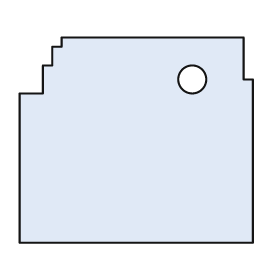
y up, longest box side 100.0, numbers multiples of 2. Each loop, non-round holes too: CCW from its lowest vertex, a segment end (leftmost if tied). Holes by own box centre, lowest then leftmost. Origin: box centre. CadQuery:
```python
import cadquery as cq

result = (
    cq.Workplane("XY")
    .moveTo(-50.0, -44.0)
    .lineTo(50.0, -44.0)
    .lineTo(50.0, 26.0)
    .lineTo(46.0, 26.0)
    .lineTo(46.0, 44.0)
    .lineTo(-32.0, 44.0)
    .lineTo(-32.0, 40.0)
    .lineTo(-36.0, 40.0)
    .lineTo(-36.0, 32.0)
    .lineTo(-40.0, 32.0)
    .lineTo(-40.0, 20.0)
    .lineTo(-50.0, 20.0)
    .close()
    .moveTo(24.0, 26.0)
    .circle(6.0)
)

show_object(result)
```